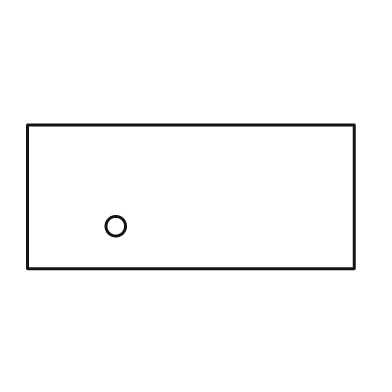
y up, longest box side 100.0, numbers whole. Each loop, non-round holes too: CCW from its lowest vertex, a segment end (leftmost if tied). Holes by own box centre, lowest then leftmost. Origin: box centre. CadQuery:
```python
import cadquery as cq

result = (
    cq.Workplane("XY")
    .moveTo(-50.0, -22.0)
    .lineTo(50.0, -22.0)
    .lineTo(50.0, 22.0)
    .lineTo(-50.0, 22.0)
    .close()
    .moveTo(-23.0, -9.0)
    .circle(3.0)
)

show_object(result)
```